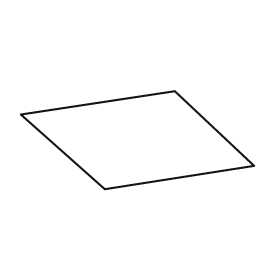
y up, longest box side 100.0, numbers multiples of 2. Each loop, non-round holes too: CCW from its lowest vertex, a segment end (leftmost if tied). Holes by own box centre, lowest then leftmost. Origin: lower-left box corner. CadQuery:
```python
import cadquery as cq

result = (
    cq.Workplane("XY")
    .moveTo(36.0, 0.0)
    .lineTo(100.0, 10.0)
    .lineTo(66.0, 42.0)
    .lineTo(0.0, 32.0)
    .close()
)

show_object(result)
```